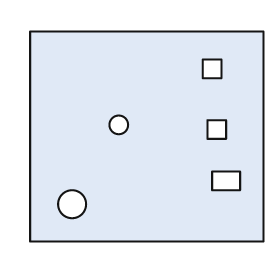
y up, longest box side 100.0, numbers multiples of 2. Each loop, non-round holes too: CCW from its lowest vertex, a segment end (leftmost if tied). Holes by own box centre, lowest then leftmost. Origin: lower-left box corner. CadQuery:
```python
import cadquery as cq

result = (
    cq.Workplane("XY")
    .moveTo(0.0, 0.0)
    .lineTo(100.0, 0.0)
    .lineTo(100.0, 90.0)
    .lineTo(0.0, 90.0)
    .close()
    .moveTo(18.0, 16.0)
    .circle(6.0)
    .moveTo(78.0, 22.0)
    .lineTo(90.0, 22.0)
    .lineTo(90.0, 30.0)
    .lineTo(78.0, 30.0)
    .close()
    .moveTo(76.0, 44.0)
    .lineTo(84.0, 44.0)
    .lineTo(84.0, 52.0)
    .lineTo(76.0, 52.0)
    .close()
    .moveTo(38.0, 50.0)
    .circle(4.0)
    .moveTo(74.0, 70.0)
    .lineTo(82.0, 70.0)
    .lineTo(82.0, 78.0)
    .lineTo(74.0, 78.0)
    .close()
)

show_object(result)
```